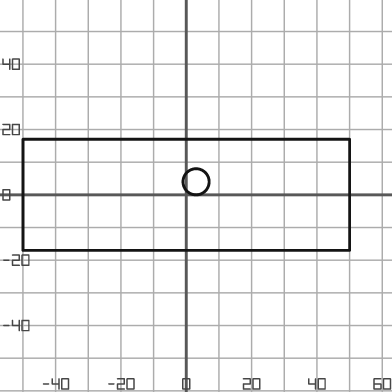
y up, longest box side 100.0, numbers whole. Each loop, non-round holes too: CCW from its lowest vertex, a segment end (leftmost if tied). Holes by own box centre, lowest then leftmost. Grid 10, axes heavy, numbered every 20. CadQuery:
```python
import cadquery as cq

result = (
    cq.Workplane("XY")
    .moveTo(-50.0, -17.0)
    .lineTo(50.0, -17.0)
    .lineTo(50.0, 17.0)
    .lineTo(-50.0, 17.0)
    .close()
    .moveTo(3.0, 4.0)
    .circle(4.0)
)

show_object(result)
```